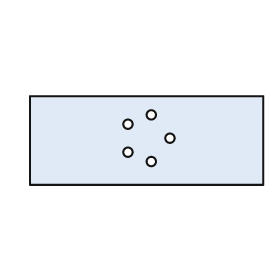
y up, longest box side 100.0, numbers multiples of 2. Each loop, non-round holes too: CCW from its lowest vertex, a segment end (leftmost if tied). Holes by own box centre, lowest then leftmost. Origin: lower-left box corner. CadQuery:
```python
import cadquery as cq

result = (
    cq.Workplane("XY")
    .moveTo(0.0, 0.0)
    .lineTo(100.0, 0.0)
    .lineTo(100.0, 38.0)
    .lineTo(0.0, 38.0)
    .close()
    .moveTo(52.0, 10.0)
    .circle(2.0)
    .moveTo(42.0, 14.0)
    .circle(2.0)
    .moveTo(60.0, 20.0)
    .circle(2.0)
    .moveTo(42.0, 26.0)
    .circle(2.0)
    .moveTo(52.0, 30.0)
    .circle(2.0)
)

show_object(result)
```